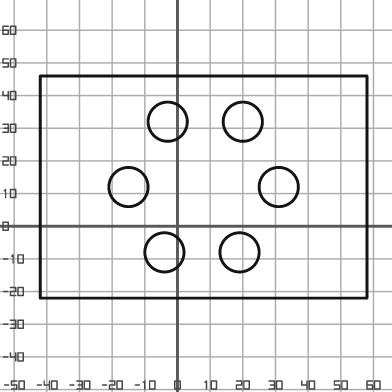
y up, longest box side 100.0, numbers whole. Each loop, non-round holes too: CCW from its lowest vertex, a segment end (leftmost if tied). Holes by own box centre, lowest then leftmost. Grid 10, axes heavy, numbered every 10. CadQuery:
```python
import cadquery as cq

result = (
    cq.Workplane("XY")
    .moveTo(-42.0, -22.0)
    .lineTo(58.0, -22.0)
    .lineTo(58.0, 46.0)
    .lineTo(-42.0, 46.0)
    .close()
    .moveTo(-4.0, -8.0)
    .circle(6.0)
    .moveTo(19.0, -8.0)
    .circle(6.0)
    .moveTo(-15.0, 12.0)
    .circle(6.0)
    .moveTo(31.0, 12.0)
    .circle(6.0)
    .moveTo(-3.0, 32.0)
    .circle(6.0)
    .moveTo(20.0, 32.0)
    .circle(6.0)
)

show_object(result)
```